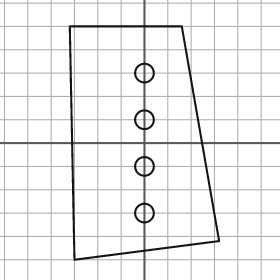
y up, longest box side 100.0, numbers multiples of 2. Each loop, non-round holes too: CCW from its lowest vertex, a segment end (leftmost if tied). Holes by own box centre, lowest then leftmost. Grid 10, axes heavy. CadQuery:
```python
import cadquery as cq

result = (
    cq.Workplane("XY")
    .moveTo(-30.0, -50.0)
    .lineTo(32.0, -42.0)
    .lineTo(16.0, 50.0)
    .lineTo(-32.0, 50.0)
    .close()
    .moveTo(0.0, -30.0)
    .circle(4.0)
    .moveTo(0.0, -10.0)
    .circle(4.0)
    .moveTo(0.0, 10.0)
    .circle(4.0)
    .moveTo(0.0, 30.0)
    .circle(4.0)
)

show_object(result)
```